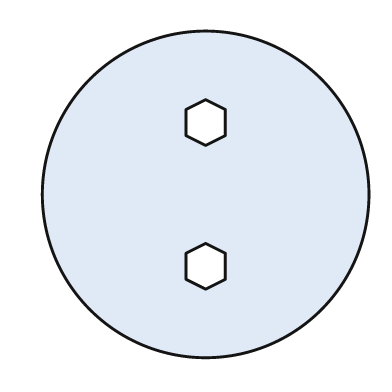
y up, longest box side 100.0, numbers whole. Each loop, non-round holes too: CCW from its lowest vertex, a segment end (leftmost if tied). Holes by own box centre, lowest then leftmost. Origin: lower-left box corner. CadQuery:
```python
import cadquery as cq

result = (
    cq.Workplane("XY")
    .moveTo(50.0, 50.0)
    .circle(50.0)
    .moveTo(50.0, 21.0)
    .lineTo(56.0, 24.0)
    .lineTo(56.0, 32.0)
    .lineTo(50.0, 35.0)
    .lineTo(44.0, 32.0)
    .lineTo(44.0, 24.0)
    .close()
    .moveTo(50.0, 65.0)
    .lineTo(56.0, 68.0)
    .lineTo(56.0, 76.0)
    .lineTo(50.0, 79.0)
    .lineTo(44.0, 76.0)
    .lineTo(44.0, 68.0)
    .close()
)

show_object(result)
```